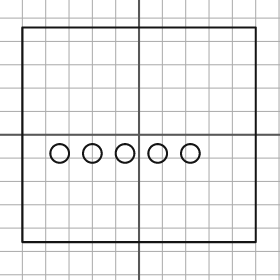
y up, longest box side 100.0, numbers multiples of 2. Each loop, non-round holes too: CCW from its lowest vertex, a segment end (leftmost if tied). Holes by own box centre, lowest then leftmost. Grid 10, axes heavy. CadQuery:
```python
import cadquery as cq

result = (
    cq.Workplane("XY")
    .moveTo(-50.0, -46.0)
    .lineTo(50.0, -46.0)
    .lineTo(50.0, 46.0)
    .lineTo(-50.0, 46.0)
    .close()
    .moveTo(-34.0, -8.0)
    .circle(4.0)
    .moveTo(-20.0, -8.0)
    .circle(4.0)
    .moveTo(-6.0, -8.0)
    .circle(4.0)
    .moveTo(8.0, -8.0)
    .circle(4.0)
    .moveTo(22.0, -8.0)
    .circle(4.0)
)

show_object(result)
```